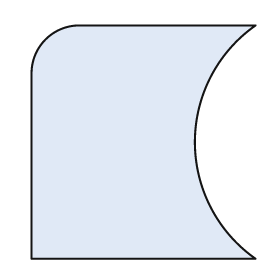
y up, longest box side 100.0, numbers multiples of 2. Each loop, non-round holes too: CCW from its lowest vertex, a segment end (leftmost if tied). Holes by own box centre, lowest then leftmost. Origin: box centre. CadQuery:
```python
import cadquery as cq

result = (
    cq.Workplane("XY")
    .moveTo(-48.0, -50.0)
    .lineTo(48.0, -50.0)
    .threePointArc((22.0, 0.0), (48.0, 50.0))
    .lineTo(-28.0, 50.0)
    .threePointArc((-42.0, 44.0), (-48.0, 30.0))
    .close()
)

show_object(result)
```